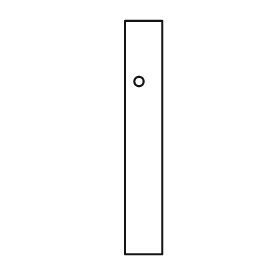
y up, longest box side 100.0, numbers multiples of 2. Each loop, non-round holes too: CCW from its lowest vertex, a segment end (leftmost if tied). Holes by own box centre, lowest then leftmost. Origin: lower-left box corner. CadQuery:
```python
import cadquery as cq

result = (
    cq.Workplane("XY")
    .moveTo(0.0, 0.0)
    .lineTo(16.0, 0.0)
    .lineTo(16.0, 100.0)
    .lineTo(0.0, 100.0)
    .close()
    .moveTo(6.0, 74.0)
    .circle(2.0)
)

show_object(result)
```